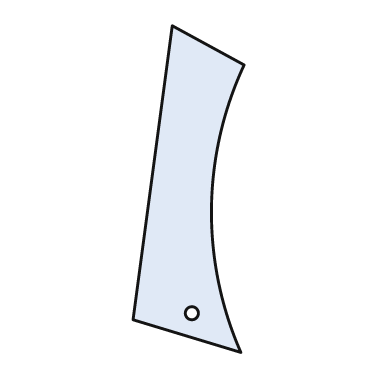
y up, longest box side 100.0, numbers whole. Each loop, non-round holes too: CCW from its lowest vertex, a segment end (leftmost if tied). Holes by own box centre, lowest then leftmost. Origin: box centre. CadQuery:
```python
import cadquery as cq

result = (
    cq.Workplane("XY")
    .moveTo(16.0, -50.0)
    .threePointArc((7.0, -6.0), (17.0, 38.0))
    .lineTo(-5.0, 50.0)
    .lineTo(-17.0, -40.0)
    .close()
    .moveTo(1.0, -38.0)
    .circle(2.0)
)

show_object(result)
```